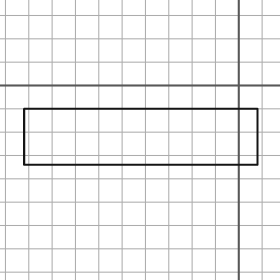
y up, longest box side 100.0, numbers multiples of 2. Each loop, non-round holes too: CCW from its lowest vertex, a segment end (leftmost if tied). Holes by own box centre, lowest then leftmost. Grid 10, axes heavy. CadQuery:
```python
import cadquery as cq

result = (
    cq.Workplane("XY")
    .moveTo(-92.0, -34.0)
    .lineTo(8.0, -34.0)
    .lineTo(8.0, -10.0)
    .lineTo(-92.0, -10.0)
    .close()
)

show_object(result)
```